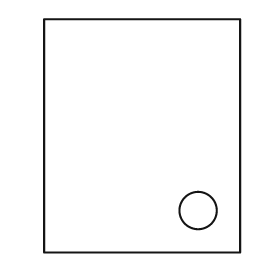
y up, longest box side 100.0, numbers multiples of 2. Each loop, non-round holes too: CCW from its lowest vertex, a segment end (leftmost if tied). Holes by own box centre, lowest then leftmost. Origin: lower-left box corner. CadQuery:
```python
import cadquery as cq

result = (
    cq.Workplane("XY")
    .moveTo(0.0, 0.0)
    .lineTo(84.0, 0.0)
    .lineTo(84.0, 100.0)
    .lineTo(0.0, 100.0)
    .close()
    .moveTo(66.0, 18.0)
    .circle(8.0)
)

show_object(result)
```